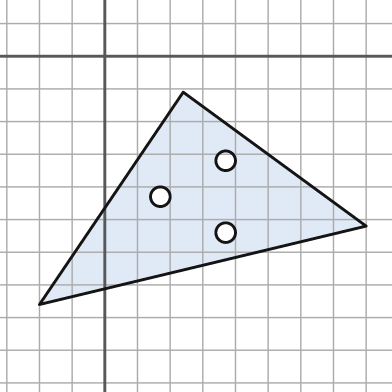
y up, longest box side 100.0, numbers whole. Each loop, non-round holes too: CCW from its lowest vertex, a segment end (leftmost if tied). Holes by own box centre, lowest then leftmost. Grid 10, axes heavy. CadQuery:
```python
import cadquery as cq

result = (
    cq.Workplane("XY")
    .moveTo(-20.0, -76.0)
    .lineTo(80.0, -52.0)
    .lineTo(24.0, -11.0)
    .close()
    .moveTo(37.0, -54.0)
    .circle(3.0)
    .moveTo(17.0, -43.0)
    .circle(3.0)
    .moveTo(37.0, -32.0)
    .circle(3.0)
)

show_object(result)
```